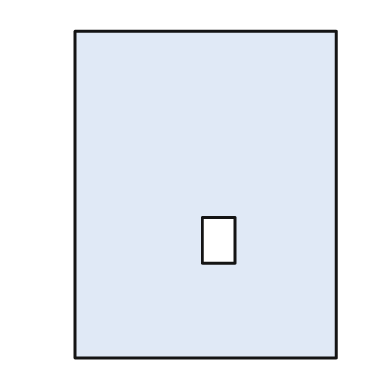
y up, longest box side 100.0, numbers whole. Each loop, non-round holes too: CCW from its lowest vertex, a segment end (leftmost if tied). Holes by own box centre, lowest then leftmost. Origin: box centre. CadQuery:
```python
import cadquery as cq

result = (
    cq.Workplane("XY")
    .moveTo(-40.0, -50.0)
    .lineTo(40.0, -50.0)
    .lineTo(40.0, 50.0)
    .lineTo(-40.0, 50.0)
    .close()
    .moveTo(-1.0, -21.0)
    .lineTo(9.0, -21.0)
    .lineTo(9.0, -7.0)
    .lineTo(-1.0, -7.0)
    .close()
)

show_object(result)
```